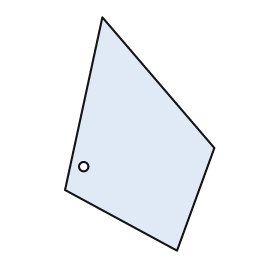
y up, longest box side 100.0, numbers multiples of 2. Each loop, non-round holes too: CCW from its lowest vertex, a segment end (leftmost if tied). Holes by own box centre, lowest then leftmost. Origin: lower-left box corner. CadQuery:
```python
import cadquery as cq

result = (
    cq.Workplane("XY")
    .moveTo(48.0, 0.0)
    .lineTo(64.0, 44.0)
    .lineTo(16.0, 100.0)
    .lineTo(0.0, 26.0)
    .close()
    .moveTo(8.0, 36.0)
    .circle(2.0)
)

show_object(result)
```